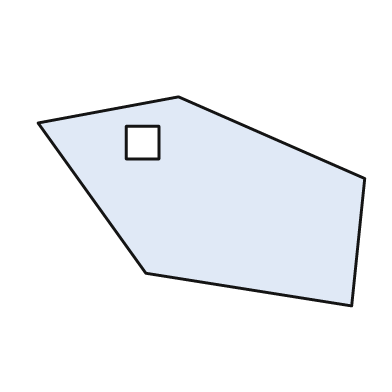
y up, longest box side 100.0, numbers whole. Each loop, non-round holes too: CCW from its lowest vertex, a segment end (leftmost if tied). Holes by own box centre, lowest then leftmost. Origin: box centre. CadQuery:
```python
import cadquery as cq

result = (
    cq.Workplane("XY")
    .moveTo(46.0, -32.0)
    .lineTo(50.0, 7.0)
    .lineTo(-7.0, 32.0)
    .lineTo(-50.0, 24.0)
    .lineTo(-17.0, -22.0)
    .close()
    .moveTo(-23.0, 13.0)
    .lineTo(-13.0, 13.0)
    .lineTo(-13.0, 23.0)
    .lineTo(-23.0, 23.0)
    .close()
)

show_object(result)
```